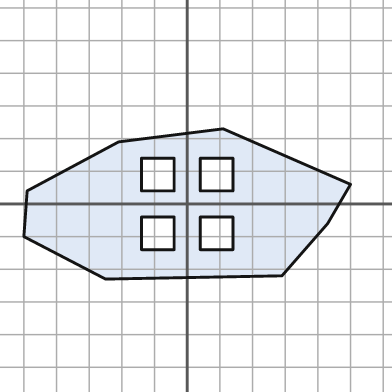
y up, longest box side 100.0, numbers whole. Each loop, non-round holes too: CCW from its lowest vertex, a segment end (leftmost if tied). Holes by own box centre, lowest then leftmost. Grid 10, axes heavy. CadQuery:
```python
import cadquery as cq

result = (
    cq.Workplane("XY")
    .moveTo(-25.0, -23.0)
    .lineTo(29.0, -22.0)
    .lineTo(43.0, -6.0)
    .lineTo(50.0, 6.0)
    .lineTo(11.0, 23.0)
    .lineTo(-21.0, 19.0)
    .lineTo(-49.0, 4.0)
    .lineTo(-50.0, -10.0)
    .close()
    .moveTo(-14.0, -14.0)
    .lineTo(-4.0, -14.0)
    .lineTo(-4.0, -4.0)
    .lineTo(-14.0, -4.0)
    .close()
    .moveTo(4.0, -14.0)
    .lineTo(14.0, -14.0)
    .lineTo(14.0, -4.0)
    .lineTo(4.0, -4.0)
    .close()
    .moveTo(-14.0, 4.0)
    .lineTo(-4.0, 4.0)
    .lineTo(-4.0, 14.0)
    .lineTo(-14.0, 14.0)
    .close()
    .moveTo(4.0, 4.0)
    .lineTo(14.0, 4.0)
    .lineTo(14.0, 14.0)
    .lineTo(4.0, 14.0)
    .close()
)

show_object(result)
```